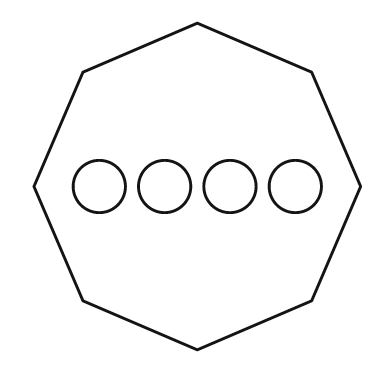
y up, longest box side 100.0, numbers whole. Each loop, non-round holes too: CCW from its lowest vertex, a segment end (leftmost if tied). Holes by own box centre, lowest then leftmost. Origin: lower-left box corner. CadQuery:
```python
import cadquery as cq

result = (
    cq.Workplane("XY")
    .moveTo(50.0, 0.0)
    .lineTo(85.0, 15.0)
    .lineTo(100.0, 50.0)
    .lineTo(85.0, 85.0)
    .lineTo(50.0, 100.0)
    .lineTo(15.0, 85.0)
    .lineTo(0.0, 50.0)
    .lineTo(15.0, 15.0)
    .close()
    .moveTo(20.0, 50.0)
    .circle(8.0)
    .moveTo(40.0, 50.0)
    .circle(8.0)
    .moveTo(60.0, 50.0)
    .circle(8.0)
    .moveTo(80.0, 50.0)
    .circle(8.0)
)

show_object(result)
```